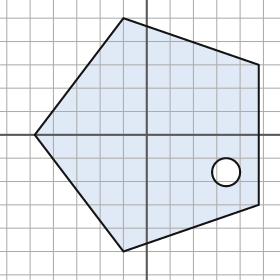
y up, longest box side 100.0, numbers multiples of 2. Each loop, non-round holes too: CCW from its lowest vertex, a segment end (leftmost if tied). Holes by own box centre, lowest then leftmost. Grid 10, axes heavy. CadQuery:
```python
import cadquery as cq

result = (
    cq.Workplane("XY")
    .moveTo(-10.0, -50.0)
    .lineTo(48.0, -30.0)
    .lineTo(48.0, 30.0)
    .lineTo(-10.0, 50.0)
    .lineTo(-48.0, 0.0)
    .close()
    .moveTo(34.0, -16.0)
    .circle(6.0)
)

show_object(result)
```